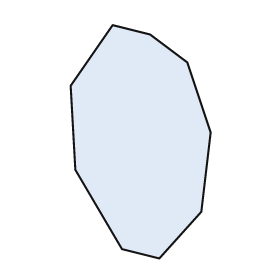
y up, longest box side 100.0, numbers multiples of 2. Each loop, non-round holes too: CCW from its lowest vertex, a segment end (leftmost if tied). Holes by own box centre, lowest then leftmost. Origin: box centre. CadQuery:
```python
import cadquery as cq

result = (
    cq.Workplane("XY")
    .moveTo(8.0, -50.0)
    .lineTo(26.0, -30.0)
    .lineTo(30.0, 4.0)
    .lineTo(20.0, 34.0)
    .lineTo(4.0, 46.0)
    .lineTo(-12.0, 50.0)
    .lineTo(-30.0, 24.0)
    .lineTo(-28.0, -12.0)
    .lineTo(-8.0, -46.0)
    .close()
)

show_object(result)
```